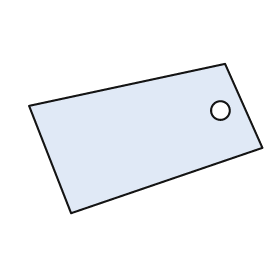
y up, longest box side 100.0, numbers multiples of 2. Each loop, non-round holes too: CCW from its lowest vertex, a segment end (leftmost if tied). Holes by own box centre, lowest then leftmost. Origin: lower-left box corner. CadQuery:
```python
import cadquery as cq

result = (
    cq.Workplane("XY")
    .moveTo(18.0, 0.0)
    .lineTo(100.0, 28.0)
    .lineTo(84.0, 64.0)
    .lineTo(0.0, 46.0)
    .close()
    .moveTo(82.0, 44.0)
    .circle(4.0)
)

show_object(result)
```